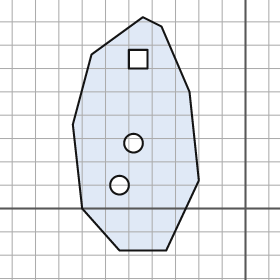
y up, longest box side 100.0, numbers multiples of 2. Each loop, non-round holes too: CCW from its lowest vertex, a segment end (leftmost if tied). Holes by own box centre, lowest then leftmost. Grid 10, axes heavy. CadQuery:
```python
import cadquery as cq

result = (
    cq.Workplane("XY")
    .moveTo(-54.0, -18.0)
    .lineTo(-34.0, -18.0)
    .lineTo(-20.0, 12.0)
    .lineTo(-24.0, 50.0)
    .lineTo(-36.0, 78.0)
    .lineTo(-44.0, 82.0)
    .lineTo(-66.0, 66.0)
    .lineTo(-74.0, 36.0)
    .lineTo(-70.0, 0.0)
    .close()
    .moveTo(-54.0, 10.0)
    .circle(4.0)
    .moveTo(-48.0, 28.0)
    .circle(4.0)
    .moveTo(-50.0, 60.0)
    .lineTo(-42.0, 60.0)
    .lineTo(-42.0, 68.0)
    .lineTo(-50.0, 68.0)
    .close()
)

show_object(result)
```